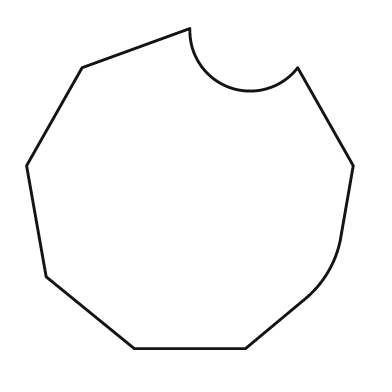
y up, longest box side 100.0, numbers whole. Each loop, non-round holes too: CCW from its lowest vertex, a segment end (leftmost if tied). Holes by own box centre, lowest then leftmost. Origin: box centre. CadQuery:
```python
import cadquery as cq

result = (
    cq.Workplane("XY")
    .moveTo(-17.0, -49.0)
    .lineTo(17.0, -49.0)
    .lineTo(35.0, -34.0)
    .threePointArc((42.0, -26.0), (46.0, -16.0))
    .lineTo(50.0, 7.0)
    .lineTo(33.0, 37.0)
    .threePointArc((12.0, 31.0), (0.0, 49.0))
    .lineTo(-33.0, 37.0)
    .lineTo(-50.0, 7.0)
    .lineTo(-44.0, -27.0)
    .close()
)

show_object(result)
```